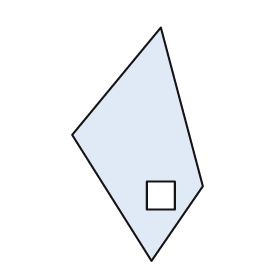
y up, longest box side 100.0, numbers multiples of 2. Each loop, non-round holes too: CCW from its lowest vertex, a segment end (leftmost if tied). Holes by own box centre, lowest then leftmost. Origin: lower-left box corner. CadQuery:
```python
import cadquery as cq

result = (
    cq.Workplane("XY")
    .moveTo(34.0, 0.0)
    .lineTo(56.0, 32.0)
    .lineTo(38.0, 100.0)
    .lineTo(0.0, 54.0)
    .close()
    .moveTo(32.0, 22.0)
    .lineTo(44.0, 22.0)
    .lineTo(44.0, 34.0)
    .lineTo(32.0, 34.0)
    .close()
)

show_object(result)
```